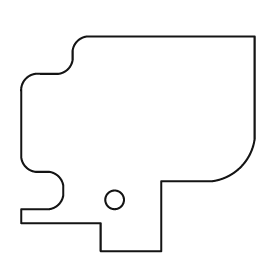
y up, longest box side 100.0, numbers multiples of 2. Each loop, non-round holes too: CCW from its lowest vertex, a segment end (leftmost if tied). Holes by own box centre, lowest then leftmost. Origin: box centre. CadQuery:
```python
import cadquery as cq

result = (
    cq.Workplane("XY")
    .moveTo(-16.0, -46.0)
    .lineTo(10.0, -46.0)
    .lineTo(10.0, -16.0)
    .lineTo(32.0, -16.0)
    .threePointArc((44.0, -10.0), (50.0, 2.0))
    .lineTo(50.0, 46.0)
    .lineTo(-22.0, 46.0)
    .threePointArc((-26.0, 44.0), (-28.0, 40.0))
    .lineTo(-28.0, 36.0)
    .threePointArc((-30.0, 32.0), (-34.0, 30.0))
    .lineTo(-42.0, 30.0)
    .threePointArc((-48.0, 28.0), (-50.0, 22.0))
    .lineTo(-50.0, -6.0)
    .threePointArc((-48.0, -10.0), (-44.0, -12.0))
    .lineTo(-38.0, -12.0)
    .threePointArc((-34.0, -14.0), (-32.0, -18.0))
    .lineTo(-32.0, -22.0)
    .threePointArc((-34.0, -26.0), (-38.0, -28.0))
    .lineTo(-50.0, -28.0)
    .lineTo(-50.0, -34.0)
    .lineTo(-16.0, -34.0)
    .close()
    .moveTo(-10.0, -24.0)
    .circle(4.0)
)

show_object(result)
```